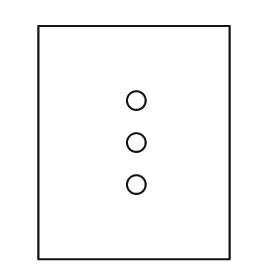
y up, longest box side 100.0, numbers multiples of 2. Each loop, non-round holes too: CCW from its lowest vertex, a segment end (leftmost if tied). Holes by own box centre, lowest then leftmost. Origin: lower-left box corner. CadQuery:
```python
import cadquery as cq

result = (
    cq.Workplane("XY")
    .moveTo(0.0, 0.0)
    .lineTo(82.0, 0.0)
    .lineTo(82.0, 100.0)
    .lineTo(0.0, 100.0)
    .close()
    .moveTo(42.0, 32.0)
    .circle(4.0)
    .moveTo(42.0, 50.0)
    .circle(4.0)
    .moveTo(42.0, 68.0)
    .circle(4.0)
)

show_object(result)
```